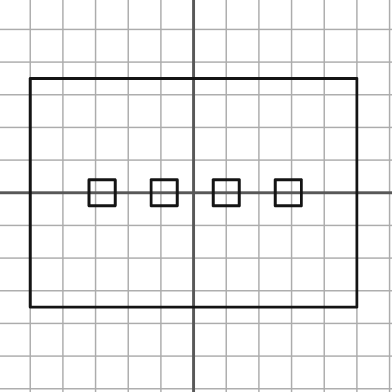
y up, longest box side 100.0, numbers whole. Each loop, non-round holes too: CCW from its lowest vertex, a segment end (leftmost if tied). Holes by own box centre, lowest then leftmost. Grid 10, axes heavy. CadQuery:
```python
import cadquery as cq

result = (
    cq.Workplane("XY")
    .moveTo(-50.0, -35.0)
    .lineTo(50.0, -35.0)
    .lineTo(50.0, 35.0)
    .lineTo(-50.0, 35.0)
    .close()
    .moveTo(-32.0, -4.0)
    .lineTo(-24.0, -4.0)
    .lineTo(-24.0, 4.0)
    .lineTo(-32.0, 4.0)
    .close()
    .moveTo(-13.0, -4.0)
    .lineTo(-5.0, -4.0)
    .lineTo(-5.0, 4.0)
    .lineTo(-13.0, 4.0)
    .close()
    .moveTo(6.0, -4.0)
    .lineTo(14.0, -4.0)
    .lineTo(14.0, 4.0)
    .lineTo(6.0, 4.0)
    .close()
    .moveTo(25.0, -4.0)
    .lineTo(33.0, -4.0)
    .lineTo(33.0, 4.0)
    .lineTo(25.0, 4.0)
    .close()
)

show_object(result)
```